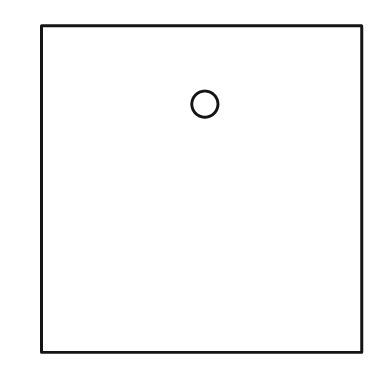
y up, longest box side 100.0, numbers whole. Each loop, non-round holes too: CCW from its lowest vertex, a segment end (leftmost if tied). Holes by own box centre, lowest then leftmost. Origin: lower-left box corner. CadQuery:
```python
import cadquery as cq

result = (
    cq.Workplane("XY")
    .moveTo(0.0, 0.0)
    .lineTo(98.0, 0.0)
    .lineTo(98.0, 100.0)
    .lineTo(0.0, 100.0)
    .close()
    .moveTo(50.0, 76.0)
    .circle(4.0)
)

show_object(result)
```